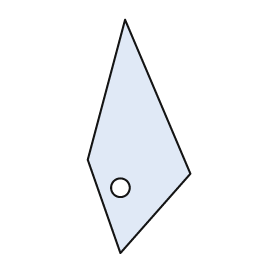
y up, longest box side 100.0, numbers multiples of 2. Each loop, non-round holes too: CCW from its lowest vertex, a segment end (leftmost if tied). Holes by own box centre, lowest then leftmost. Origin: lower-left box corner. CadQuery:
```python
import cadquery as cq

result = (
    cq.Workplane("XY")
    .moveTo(14.0, 0.0)
    .lineTo(44.0, 34.0)
    .lineTo(16.0, 100.0)
    .lineTo(0.0, 40.0)
    .close()
    .moveTo(14.0, 28.0)
    .circle(4.0)
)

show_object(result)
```